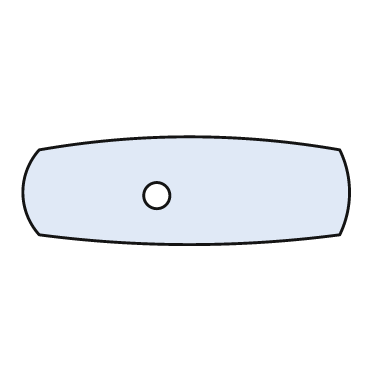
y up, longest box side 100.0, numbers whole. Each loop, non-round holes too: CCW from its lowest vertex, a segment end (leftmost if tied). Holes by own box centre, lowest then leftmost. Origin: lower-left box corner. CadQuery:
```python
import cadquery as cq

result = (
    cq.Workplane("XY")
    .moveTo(5.0, 3.0)
    .threePointArc((51.0, 0.0), (97.0, 3.0))
    .threePointArc((100.0, 16.0), (97.0, 29.0))
    .threePointArc((51.0, 33.0), (5.0, 29.0))
    .threePointArc((0.0, 16.0), (5.0, 3.0))
    .close()
    .moveTo(41.0, 15.0)
    .circle(4.0)
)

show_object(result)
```